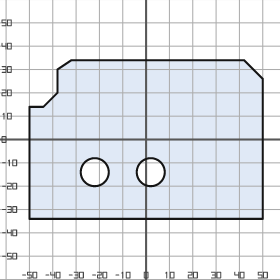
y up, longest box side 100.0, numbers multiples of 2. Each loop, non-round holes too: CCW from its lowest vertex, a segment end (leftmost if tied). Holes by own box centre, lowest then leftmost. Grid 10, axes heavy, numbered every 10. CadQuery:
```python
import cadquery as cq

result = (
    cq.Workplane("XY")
    .moveTo(-50.0, -34.0)
    .lineTo(50.0, -34.0)
    .lineTo(50.0, 26.0)
    .lineTo(42.0, 34.0)
    .lineTo(-32.0, 34.0)
    .lineTo(-38.0, 30.0)
    .lineTo(-38.0, 20.0)
    .lineTo(-44.0, 14.0)
    .lineTo(-50.0, 14.0)
    .close()
    .moveTo(-22.0, -14.0)
    .circle(6.0)
    .moveTo(2.0, -14.0)
    .circle(6.0)
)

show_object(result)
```